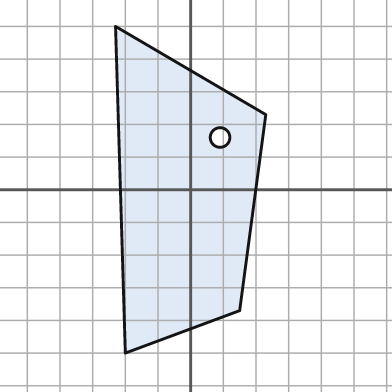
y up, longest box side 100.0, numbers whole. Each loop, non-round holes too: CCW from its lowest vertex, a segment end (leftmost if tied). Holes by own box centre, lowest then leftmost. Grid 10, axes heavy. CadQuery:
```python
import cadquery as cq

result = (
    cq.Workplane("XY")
    .moveTo(-20.0, -50.0)
    .lineTo(15.0, -37.0)
    .lineTo(23.0, 23.0)
    .lineTo(-23.0, 50.0)
    .close()
    .moveTo(9.0, 16.0)
    .circle(3.0)
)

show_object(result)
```